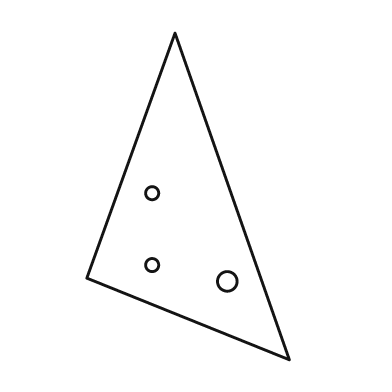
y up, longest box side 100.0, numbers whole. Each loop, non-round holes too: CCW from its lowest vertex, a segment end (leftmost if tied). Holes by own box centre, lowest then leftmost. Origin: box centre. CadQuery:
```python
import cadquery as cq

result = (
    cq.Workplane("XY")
    .moveTo(31.0, -50.0)
    .lineTo(-4.0, 50.0)
    .lineTo(-31.0, -25.0)
    .close()
    .moveTo(12.0, -26.0)
    .circle(3.0)
    .moveTo(-11.0, -21.0)
    .circle(2.0)
    .moveTo(-11.0, 1.0)
    .circle(2.0)
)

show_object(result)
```